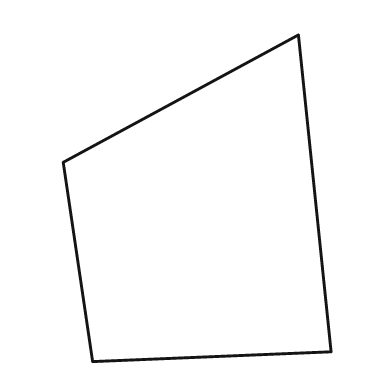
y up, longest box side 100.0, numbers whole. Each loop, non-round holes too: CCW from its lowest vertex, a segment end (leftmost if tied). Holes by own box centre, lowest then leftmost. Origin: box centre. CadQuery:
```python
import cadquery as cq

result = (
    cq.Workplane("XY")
    .moveTo(-32.0, -50.0)
    .lineTo(41.0, -47.0)
    .lineTo(31.0, 50.0)
    .lineTo(-41.0, 11.0)
    .close()
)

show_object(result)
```